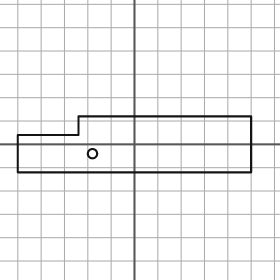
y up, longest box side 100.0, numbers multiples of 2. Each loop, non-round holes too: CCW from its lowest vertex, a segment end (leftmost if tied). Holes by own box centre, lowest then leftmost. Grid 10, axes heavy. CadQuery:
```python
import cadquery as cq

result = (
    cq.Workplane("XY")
    .moveTo(-50.0, -12.0)
    .lineTo(50.0, -12.0)
    .lineTo(50.0, 12.0)
    .lineTo(-24.0, 12.0)
    .lineTo(-24.0, 4.0)
    .lineTo(-50.0, 4.0)
    .close()
    .moveTo(-18.0, -4.0)
    .circle(2.0)
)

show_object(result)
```